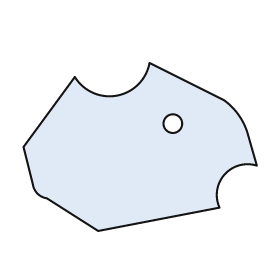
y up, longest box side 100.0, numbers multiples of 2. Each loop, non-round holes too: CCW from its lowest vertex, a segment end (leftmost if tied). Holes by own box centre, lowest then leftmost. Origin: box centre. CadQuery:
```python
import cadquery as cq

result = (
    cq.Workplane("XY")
    .moveTo(-18.0, -36.0)
    .lineTo(34.0, -26.0)
    .threePointArc((36.0, -12.0), (50.0, -8.0))
    .lineTo(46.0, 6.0)
    .threePointArc((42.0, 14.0), (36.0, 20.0))
    .lineTo(4.0, 36.0)
    .threePointArc((-10.0, 22.0), (-28.0, 30.0))
    .lineTo(-50.0, 0.0)
    .lineTo(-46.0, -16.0)
    .threePointArc((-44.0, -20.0), (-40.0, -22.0))
    .close()
    .moveTo(14.0, 10.0)
    .circle(4.0)
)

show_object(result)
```